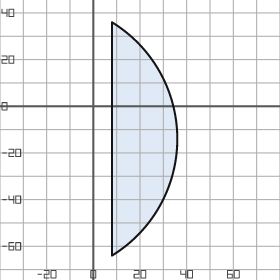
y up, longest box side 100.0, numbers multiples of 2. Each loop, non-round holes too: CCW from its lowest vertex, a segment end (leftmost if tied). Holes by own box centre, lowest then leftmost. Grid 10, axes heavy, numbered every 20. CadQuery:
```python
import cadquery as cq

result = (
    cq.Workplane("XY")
    .moveTo(8.0, -64.0)
    .threePointArc((36.0, -14.0), (8.0, 36.0))
    .close()
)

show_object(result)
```